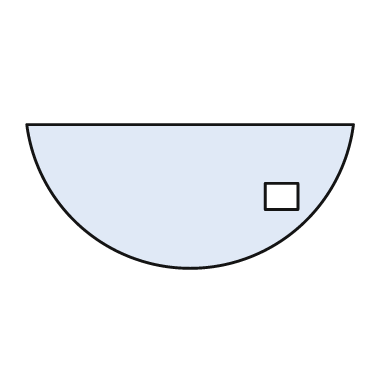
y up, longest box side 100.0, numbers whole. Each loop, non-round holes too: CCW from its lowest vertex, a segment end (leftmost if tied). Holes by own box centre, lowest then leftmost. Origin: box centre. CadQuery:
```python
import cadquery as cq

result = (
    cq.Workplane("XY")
    .moveTo(-50.0, 22.0)
    .threePointArc((0.0, -22.0), (50.0, 22.0))
    .close()
    .moveTo(23.0, -4.0)
    .lineTo(33.0, -4.0)
    .lineTo(33.0, 4.0)
    .lineTo(23.0, 4.0)
    .close()
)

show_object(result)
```